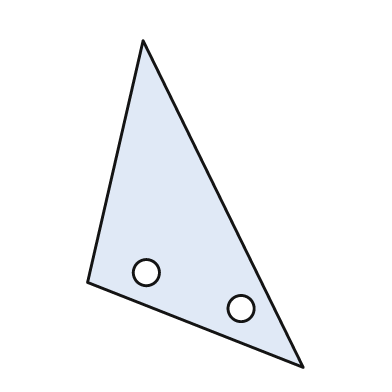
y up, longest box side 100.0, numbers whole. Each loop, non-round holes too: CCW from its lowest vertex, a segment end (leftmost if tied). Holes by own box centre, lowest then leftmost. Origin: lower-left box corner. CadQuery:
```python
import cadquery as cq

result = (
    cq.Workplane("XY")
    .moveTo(66.0, 0.0)
    .lineTo(17.0, 100.0)
    .lineTo(0.0, 26.0)
    .close()
    .moveTo(47.0, 18.0)
    .circle(4.0)
    .moveTo(18.0, 29.0)
    .circle(4.0)
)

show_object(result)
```